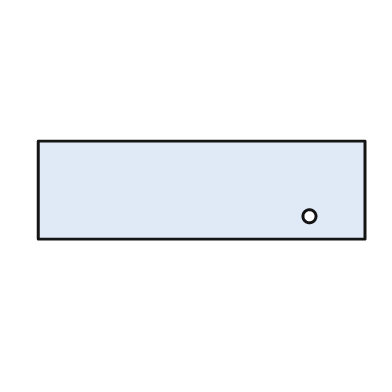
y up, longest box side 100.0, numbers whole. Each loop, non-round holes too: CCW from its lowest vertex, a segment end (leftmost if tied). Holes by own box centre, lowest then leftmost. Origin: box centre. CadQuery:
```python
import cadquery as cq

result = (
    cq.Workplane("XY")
    .moveTo(-50.0, -15.0)
    .lineTo(50.0, -15.0)
    .lineTo(50.0, 15.0)
    .lineTo(-50.0, 15.0)
    .close()
    .moveTo(33.0, -8.0)
    .circle(2.0)
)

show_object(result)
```